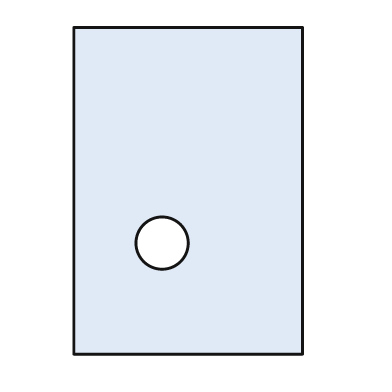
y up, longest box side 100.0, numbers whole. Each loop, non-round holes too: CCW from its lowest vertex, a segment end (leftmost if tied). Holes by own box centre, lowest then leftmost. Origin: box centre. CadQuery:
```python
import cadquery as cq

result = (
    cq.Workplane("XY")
    .moveTo(-35.0, -50.0)
    .lineTo(35.0, -50.0)
    .lineTo(35.0, 50.0)
    .lineTo(-35.0, 50.0)
    .close()
    .moveTo(-8.0, -16.0)
    .circle(8.0)
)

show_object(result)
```